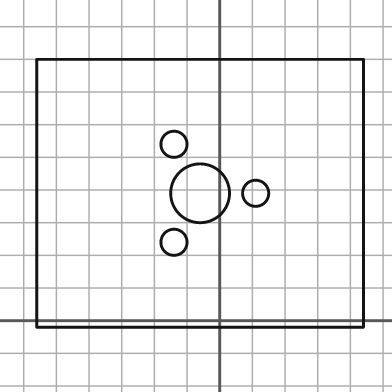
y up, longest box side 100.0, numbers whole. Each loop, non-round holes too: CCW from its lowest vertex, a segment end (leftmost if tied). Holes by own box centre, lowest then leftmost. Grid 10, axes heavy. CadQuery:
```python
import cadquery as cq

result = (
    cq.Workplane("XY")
    .moveTo(-56.0, -2.0)
    .lineTo(44.0, -2.0)
    .lineTo(44.0, 80.0)
    .lineTo(-56.0, 80.0)
    .close()
    .moveTo(-14.0, 24.0)
    .circle(4.0)
    .moveTo(-6.0, 39.0)
    .circle(9.0)
    .moveTo(11.0, 39.0)
    .circle(4.0)
    .moveTo(-14.0, 54.0)
    .circle(4.0)
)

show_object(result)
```